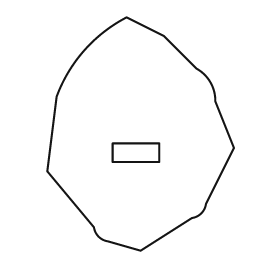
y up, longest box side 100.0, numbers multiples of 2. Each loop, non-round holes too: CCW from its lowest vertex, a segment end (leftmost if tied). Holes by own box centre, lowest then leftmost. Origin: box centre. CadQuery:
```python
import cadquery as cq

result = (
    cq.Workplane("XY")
    .moveTo(0.0, -50.0)
    .lineTo(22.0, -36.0)
    .threePointArc((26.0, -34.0), (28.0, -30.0))
    .lineTo(40.0, -6.0)
    .lineTo(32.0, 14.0)
    .threePointArc((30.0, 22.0), (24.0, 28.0))
    .lineTo(10.0, 42.0)
    .lineTo(-6.0, 50.0)
    .threePointArc((-24.0, 36.0), (-36.0, 16.0))
    .lineTo(-40.0, -16.0)
    .lineTo(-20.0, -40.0)
    .threePointArc((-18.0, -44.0), (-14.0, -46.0))
    .close()
    .moveTo(-12.0, -12.0)
    .lineTo(8.0, -12.0)
    .lineTo(8.0, -4.0)
    .lineTo(-12.0, -4.0)
    .close()
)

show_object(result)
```